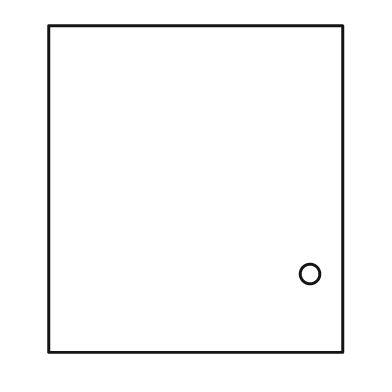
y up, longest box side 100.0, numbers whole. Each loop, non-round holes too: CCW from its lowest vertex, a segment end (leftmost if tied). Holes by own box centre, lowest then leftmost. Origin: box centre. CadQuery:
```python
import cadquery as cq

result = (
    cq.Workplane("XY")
    .moveTo(-45.0, -50.0)
    .lineTo(45.0, -50.0)
    .lineTo(45.0, 50.0)
    .lineTo(-45.0, 50.0)
    .close()
    .moveTo(35.0, -26.0)
    .circle(3.0)
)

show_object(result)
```